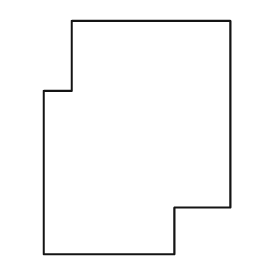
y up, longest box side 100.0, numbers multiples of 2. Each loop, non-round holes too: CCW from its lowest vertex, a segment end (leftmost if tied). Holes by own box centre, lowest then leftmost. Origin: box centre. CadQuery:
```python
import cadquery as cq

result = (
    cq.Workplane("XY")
    .moveTo(-40.0, -50.0)
    .lineTo(16.0, -50.0)
    .lineTo(16.0, -30.0)
    .lineTo(40.0, -30.0)
    .lineTo(40.0, 50.0)
    .lineTo(-28.0, 50.0)
    .lineTo(-28.0, 20.0)
    .lineTo(-40.0, 20.0)
    .close()
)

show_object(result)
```